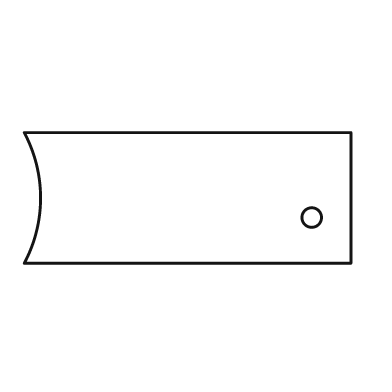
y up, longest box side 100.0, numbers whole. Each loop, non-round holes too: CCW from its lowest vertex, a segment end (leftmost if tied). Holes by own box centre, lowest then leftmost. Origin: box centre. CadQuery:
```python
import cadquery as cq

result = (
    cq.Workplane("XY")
    .moveTo(-50.0, -20.0)
    .lineTo(50.0, -20.0)
    .lineTo(50.0, 20.0)
    .lineTo(-50.0, 20.0)
    .threePointArc((-45.0, 0.0), (-50.0, -20.0))
    .close()
    .moveTo(38.0, -6.0)
    .circle(3.0)
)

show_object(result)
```